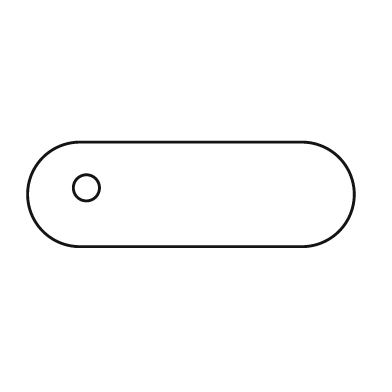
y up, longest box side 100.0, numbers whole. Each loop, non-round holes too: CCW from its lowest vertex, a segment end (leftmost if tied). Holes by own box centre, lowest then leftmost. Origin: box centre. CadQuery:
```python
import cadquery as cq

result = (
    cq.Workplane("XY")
    .moveTo(-34.0, -16.0)
    .lineTo(34.0, -16.0)
    .threePointArc((50.0, 0.0), (34.0, 16.0))
    .lineTo(-34.0, 16.0)
    .threePointArc((-50.0, 0.0), (-34.0, -16.0))
    .close()
    .moveTo(-32.0, 2.0)
    .circle(4.0)
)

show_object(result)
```